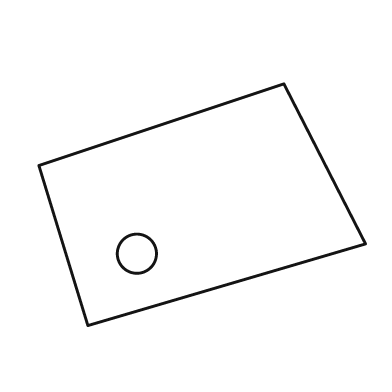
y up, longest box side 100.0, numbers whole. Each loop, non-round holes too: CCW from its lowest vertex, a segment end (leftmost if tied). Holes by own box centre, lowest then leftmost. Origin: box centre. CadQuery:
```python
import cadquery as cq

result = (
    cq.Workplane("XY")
    .moveTo(-35.0, -37.0)
    .lineTo(50.0, -12.0)
    .lineTo(25.0, 37.0)
    .lineTo(-50.0, 12.0)
    .close()
    .moveTo(-20.0, -15.0)
    .circle(6.0)
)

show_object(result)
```